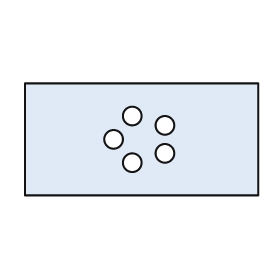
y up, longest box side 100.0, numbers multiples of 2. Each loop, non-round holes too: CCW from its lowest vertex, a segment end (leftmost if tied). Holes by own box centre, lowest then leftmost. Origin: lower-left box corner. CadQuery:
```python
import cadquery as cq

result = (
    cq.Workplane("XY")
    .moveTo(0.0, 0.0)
    .lineTo(100.0, 0.0)
    .lineTo(100.0, 48.0)
    .lineTo(0.0, 48.0)
    .close()
    .moveTo(46.0, 14.0)
    .circle(4.0)
    .moveTo(60.0, 18.0)
    .circle(4.0)
    .moveTo(38.0, 24.0)
    .circle(4.0)
    .moveTo(60.0, 30.0)
    .circle(4.0)
    .moveTo(46.0, 34.0)
    .circle(4.0)
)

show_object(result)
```